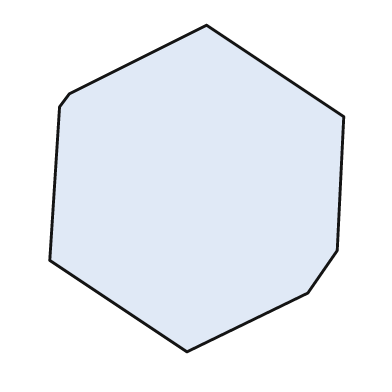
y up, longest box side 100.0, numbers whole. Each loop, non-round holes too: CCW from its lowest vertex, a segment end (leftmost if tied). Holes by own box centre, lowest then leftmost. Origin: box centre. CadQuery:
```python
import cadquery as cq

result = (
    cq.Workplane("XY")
    .moveTo(-3.0, -50.0)
    .lineTo(34.0, -32.0)
    .lineTo(43.0, -19.0)
    .lineTo(45.0, 22.0)
    .lineTo(3.0, 50.0)
    .lineTo(-39.0, 29.0)
    .lineTo(-42.0, 25.0)
    .lineTo(-45.0, -22.0)
    .close()
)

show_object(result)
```